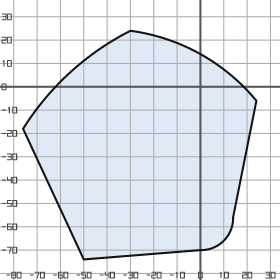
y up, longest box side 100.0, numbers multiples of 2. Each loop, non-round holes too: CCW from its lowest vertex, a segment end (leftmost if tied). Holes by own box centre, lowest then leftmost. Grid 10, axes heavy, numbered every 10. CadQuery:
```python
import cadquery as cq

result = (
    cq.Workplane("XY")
    .moveTo(-50.0, -74.0)
    .lineTo(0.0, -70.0)
    .threePointArc((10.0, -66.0), (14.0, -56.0))
    .lineTo(24.0, -6.0)
    .threePointArc((0.0, 14.0), (-30.0, 24.0))
    .threePointArc((-56.0, 6.0), (-76.0, -18.0))
    .close()
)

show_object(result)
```